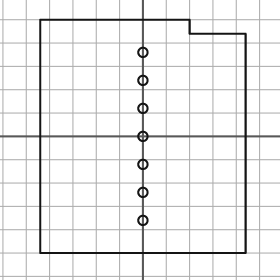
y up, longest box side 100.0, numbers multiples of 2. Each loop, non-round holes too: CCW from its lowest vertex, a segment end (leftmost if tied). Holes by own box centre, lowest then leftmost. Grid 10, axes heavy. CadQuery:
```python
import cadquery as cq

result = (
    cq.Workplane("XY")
    .moveTo(-44.0, -50.0)
    .lineTo(44.0, -50.0)
    .lineTo(44.0, 44.0)
    .lineTo(20.0, 44.0)
    .lineTo(20.0, 50.0)
    .lineTo(-44.0, 50.0)
    .close()
    .moveTo(0.0, -36.0)
    .circle(2.0)
    .moveTo(0.0, -24.0)
    .circle(2.0)
    .moveTo(0.0, -12.0)
    .circle(2.0)
    .moveTo(0.0, 0.0)
    .circle(2.0)
    .moveTo(0.0, 12.0)
    .circle(2.0)
    .moveTo(0.0, 24.0)
    .circle(2.0)
    .moveTo(0.0, 36.0)
    .circle(2.0)
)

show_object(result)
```